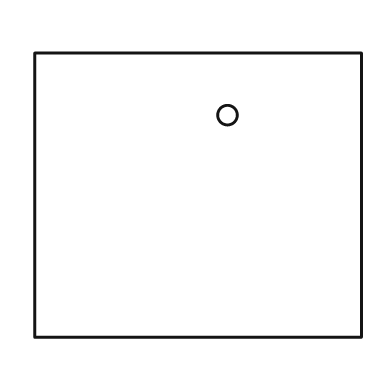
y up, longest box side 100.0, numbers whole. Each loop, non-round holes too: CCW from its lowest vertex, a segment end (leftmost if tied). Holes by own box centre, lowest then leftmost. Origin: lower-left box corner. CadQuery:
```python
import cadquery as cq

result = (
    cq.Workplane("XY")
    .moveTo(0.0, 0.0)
    .lineTo(100.0, 0.0)
    .lineTo(100.0, 87.0)
    .lineTo(0.0, 87.0)
    .close()
    .moveTo(59.0, 68.0)
    .circle(3.0)
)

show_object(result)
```